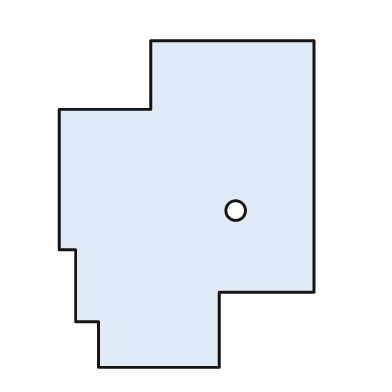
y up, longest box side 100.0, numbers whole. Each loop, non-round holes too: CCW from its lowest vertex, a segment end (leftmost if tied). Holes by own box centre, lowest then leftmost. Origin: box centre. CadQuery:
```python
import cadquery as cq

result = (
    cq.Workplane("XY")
    .moveTo(-27.0, -50.0)
    .lineTo(10.0, -50.0)
    .lineTo(10.0, -27.0)
    .lineTo(39.0, -27.0)
    .lineTo(39.0, 50.0)
    .lineTo(-11.0, 50.0)
    .lineTo(-11.0, 29.0)
    .lineTo(-39.0, 29.0)
    .lineTo(-39.0, -14.0)
    .lineTo(-34.0, -14.0)
    .lineTo(-34.0, -36.0)
    .lineTo(-27.0, -36.0)
    .close()
    .moveTo(15.0, -2.0)
    .circle(3.0)
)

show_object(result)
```